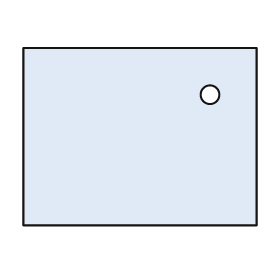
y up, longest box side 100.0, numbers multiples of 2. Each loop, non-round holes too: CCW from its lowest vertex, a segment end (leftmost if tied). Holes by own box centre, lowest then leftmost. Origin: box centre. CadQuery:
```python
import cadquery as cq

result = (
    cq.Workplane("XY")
    .moveTo(-50.0, -38.0)
    .lineTo(50.0, -38.0)
    .lineTo(50.0, 38.0)
    .lineTo(-50.0, 38.0)
    .close()
    .moveTo(30.0, 18.0)
    .circle(4.0)
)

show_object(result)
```